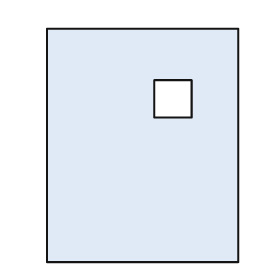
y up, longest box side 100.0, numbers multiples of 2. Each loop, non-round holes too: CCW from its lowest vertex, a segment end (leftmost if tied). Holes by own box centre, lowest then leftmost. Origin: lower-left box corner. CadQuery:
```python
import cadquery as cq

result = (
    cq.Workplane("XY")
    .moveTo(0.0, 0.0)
    .lineTo(82.0, 0.0)
    .lineTo(82.0, 100.0)
    .lineTo(0.0, 100.0)
    .close()
    .moveTo(46.0, 62.0)
    .lineTo(62.0, 62.0)
    .lineTo(62.0, 78.0)
    .lineTo(46.0, 78.0)
    .close()
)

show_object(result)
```